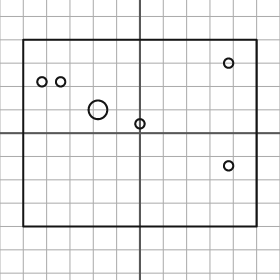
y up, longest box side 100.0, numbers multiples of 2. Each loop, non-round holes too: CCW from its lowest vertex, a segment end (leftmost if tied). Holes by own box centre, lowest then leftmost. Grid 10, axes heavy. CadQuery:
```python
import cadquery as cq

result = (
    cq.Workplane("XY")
    .moveTo(-50.0, -40.0)
    .lineTo(50.0, -40.0)
    .lineTo(50.0, 40.0)
    .lineTo(-50.0, 40.0)
    .close()
    .moveTo(38.0, -14.0)
    .circle(2.0)
    .moveTo(0.0, 4.0)
    .circle(2.0)
    .moveTo(-18.0, 10.0)
    .circle(4.0)
    .moveTo(-42.0, 22.0)
    .circle(2.0)
    .moveTo(-34.0, 22.0)
    .circle(2.0)
    .moveTo(38.0, 30.0)
    .circle(2.0)
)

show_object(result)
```